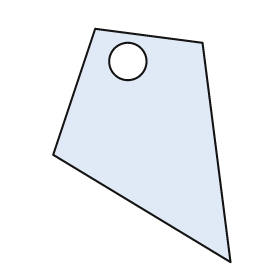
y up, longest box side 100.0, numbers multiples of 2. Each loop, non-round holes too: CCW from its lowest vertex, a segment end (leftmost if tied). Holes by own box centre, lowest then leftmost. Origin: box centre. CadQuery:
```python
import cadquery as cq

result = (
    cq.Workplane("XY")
    .moveTo(38.0, -50.0)
    .lineTo(26.0, 44.0)
    .lineTo(-20.0, 50.0)
    .lineTo(-38.0, -4.0)
    .close()
    .moveTo(-6.0, 36.0)
    .circle(8.0)
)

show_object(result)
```